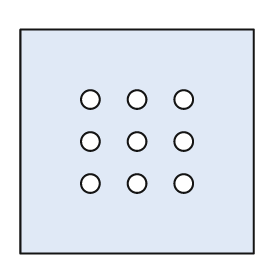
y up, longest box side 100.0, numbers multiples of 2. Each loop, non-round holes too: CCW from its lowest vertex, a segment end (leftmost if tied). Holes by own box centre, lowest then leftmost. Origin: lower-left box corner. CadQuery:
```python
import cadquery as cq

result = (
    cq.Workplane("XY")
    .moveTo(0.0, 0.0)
    .lineTo(100.0, 0.0)
    .lineTo(100.0, 96.0)
    .lineTo(0.0, 96.0)
    .close()
    .moveTo(30.0, 30.0)
    .circle(4.0)
    .moveTo(50.0, 30.0)
    .circle(4.0)
    .moveTo(70.0, 30.0)
    .circle(4.0)
    .moveTo(30.0, 48.0)
    .circle(4.0)
    .moveTo(50.0, 48.0)
    .circle(4.0)
    .moveTo(70.0, 48.0)
    .circle(4.0)
    .moveTo(30.0, 66.0)
    .circle(4.0)
    .moveTo(50.0, 66.0)
    .circle(4.0)
    .moveTo(70.0, 66.0)
    .circle(4.0)
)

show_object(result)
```